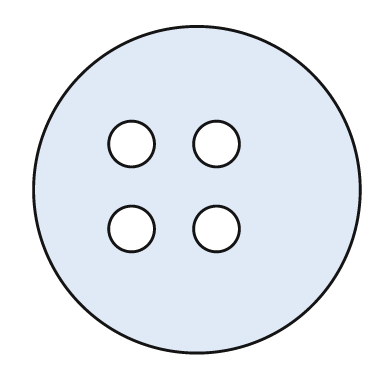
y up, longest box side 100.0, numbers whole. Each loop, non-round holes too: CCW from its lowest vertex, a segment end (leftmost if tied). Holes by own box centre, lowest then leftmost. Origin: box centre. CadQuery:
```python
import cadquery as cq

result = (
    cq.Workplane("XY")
    .moveTo(0.0, 0.0)
    .circle(50.0)
    .moveTo(-20.0, -12.0)
    .circle(7.0)
    .moveTo(6.0, -12.0)
    .circle(7.0)
    .moveTo(-20.0, 14.0)
    .circle(7.0)
    .moveTo(6.0, 14.0)
    .circle(7.0)
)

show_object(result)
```